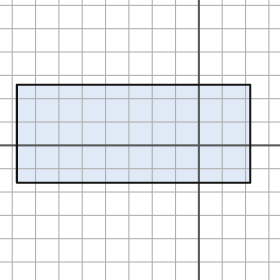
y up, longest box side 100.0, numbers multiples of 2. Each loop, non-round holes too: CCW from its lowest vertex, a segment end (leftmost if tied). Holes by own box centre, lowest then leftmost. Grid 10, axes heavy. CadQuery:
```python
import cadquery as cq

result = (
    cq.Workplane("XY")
    .moveTo(-78.0, -16.0)
    .lineTo(22.0, -16.0)
    .lineTo(22.0, 26.0)
    .lineTo(-78.0, 26.0)
    .close()
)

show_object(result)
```